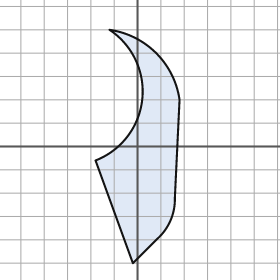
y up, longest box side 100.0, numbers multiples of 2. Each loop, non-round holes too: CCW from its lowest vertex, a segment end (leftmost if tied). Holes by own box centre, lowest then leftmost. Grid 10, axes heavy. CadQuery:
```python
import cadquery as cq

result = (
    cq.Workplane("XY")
    .moveTo(-2.0, -50.0)
    .lineTo(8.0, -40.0)
    .threePointArc((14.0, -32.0), (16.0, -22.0))
    .lineTo(18.0, 20.0)
    .threePointArc((8.0, 40.0), (-12.0, 50.0))
    .threePointArc((2.0, 20.0), (-18.0, -6.0))
    .close()
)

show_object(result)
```